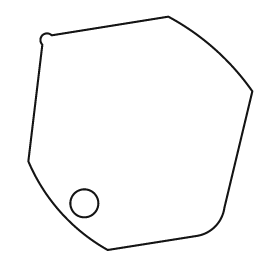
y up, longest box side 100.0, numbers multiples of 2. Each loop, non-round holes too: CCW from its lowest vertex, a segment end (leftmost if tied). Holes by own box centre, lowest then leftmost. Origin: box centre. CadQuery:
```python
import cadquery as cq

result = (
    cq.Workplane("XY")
    .moveTo(-14.0, -50.0)
    .lineTo(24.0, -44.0)
    .threePointArc((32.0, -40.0), (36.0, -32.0))
    .lineTo(48.0, 18.0)
    .threePointArc((32.0, 36.0), (12.0, 50.0))
    .lineTo(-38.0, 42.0)
    .threePointArc((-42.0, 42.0), (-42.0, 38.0))
    .lineTo(-48.0, -12.0)
    .threePointArc((-34.0, -34.0), (-14.0, -50.0))
    .close()
    .moveTo(-24.0, -30.0)
    .circle(6.0)
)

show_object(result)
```